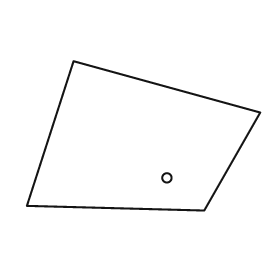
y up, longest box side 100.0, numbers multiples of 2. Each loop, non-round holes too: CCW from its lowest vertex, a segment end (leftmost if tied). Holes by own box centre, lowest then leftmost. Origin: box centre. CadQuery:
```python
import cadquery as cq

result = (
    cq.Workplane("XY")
    .moveTo(26.0, -32.0)
    .lineTo(50.0, 10.0)
    .lineTo(-30.0, 32.0)
    .lineTo(-50.0, -30.0)
    .close()
    .moveTo(10.0, -18.0)
    .circle(2.0)
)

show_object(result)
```